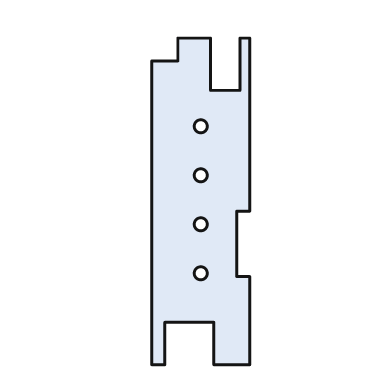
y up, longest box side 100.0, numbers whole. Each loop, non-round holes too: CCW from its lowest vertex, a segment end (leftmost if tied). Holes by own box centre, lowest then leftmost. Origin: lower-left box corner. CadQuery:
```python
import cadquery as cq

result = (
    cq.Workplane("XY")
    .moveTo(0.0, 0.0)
    .lineTo(4.0, 0.0)
    .lineTo(4.0, 13.0)
    .lineTo(19.0, 13.0)
    .lineTo(19.0, 0.0)
    .lineTo(30.0, 0.0)
    .lineTo(30.0, 27.0)
    .lineTo(26.0, 27.0)
    .lineTo(26.0, 47.0)
    .lineTo(30.0, 47.0)
    .lineTo(30.0, 100.0)
    .lineTo(27.0, 100.0)
    .lineTo(27.0, 84.0)
    .lineTo(18.0, 84.0)
    .lineTo(18.0, 100.0)
    .lineTo(8.0, 100.0)
    .lineTo(8.0, 93.0)
    .lineTo(0.0, 93.0)
    .close()
    .moveTo(15.0, 28.0)
    .circle(2.0)
    .moveTo(15.0, 43.0)
    .circle(2.0)
    .moveTo(15.0, 58.0)
    .circle(2.0)
    .moveTo(15.0, 73.0)
    .circle(2.0)
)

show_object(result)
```